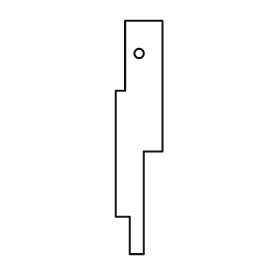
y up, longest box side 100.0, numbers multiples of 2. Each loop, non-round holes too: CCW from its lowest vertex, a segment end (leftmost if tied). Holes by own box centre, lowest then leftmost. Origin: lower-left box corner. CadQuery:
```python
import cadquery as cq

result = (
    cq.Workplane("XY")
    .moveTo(6.0, 0.0)
    .lineTo(12.0, 0.0)
    .lineTo(12.0, 44.0)
    .lineTo(20.0, 44.0)
    .lineTo(20.0, 100.0)
    .lineTo(4.0, 100.0)
    .lineTo(4.0, 70.0)
    .lineTo(0.0, 70.0)
    .lineTo(0.0, 16.0)
    .lineTo(6.0, 16.0)
    .close()
    .moveTo(10.0, 86.0)
    .circle(2.0)
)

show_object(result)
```